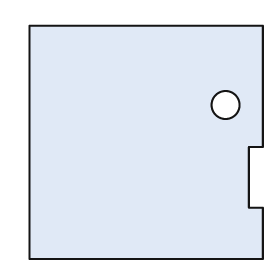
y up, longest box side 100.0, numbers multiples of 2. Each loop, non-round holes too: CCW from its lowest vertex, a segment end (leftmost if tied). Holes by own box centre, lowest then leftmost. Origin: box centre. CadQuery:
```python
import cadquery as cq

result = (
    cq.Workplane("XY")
    .moveTo(-50.0, -50.0)
    .lineTo(50.0, -50.0)
    .lineTo(50.0, -28.0)
    .lineTo(44.0, -28.0)
    .lineTo(44.0, -2.0)
    .lineTo(50.0, -2.0)
    .lineTo(50.0, 50.0)
    .lineTo(-50.0, 50.0)
    .close()
    .moveTo(34.0, 16.0)
    .circle(6.0)
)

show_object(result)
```